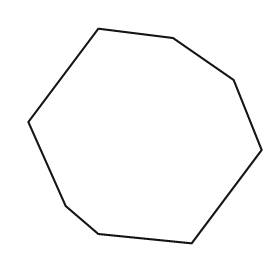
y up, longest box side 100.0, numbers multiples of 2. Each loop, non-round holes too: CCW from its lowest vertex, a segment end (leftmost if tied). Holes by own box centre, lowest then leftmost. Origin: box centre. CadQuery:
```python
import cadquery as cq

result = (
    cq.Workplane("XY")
    .moveTo(20.0, -46.0)
    .lineTo(50.0, -6.0)
    .lineTo(38.0, 24.0)
    .lineTo(12.0, 42.0)
    .lineTo(-20.0, 46.0)
    .lineTo(-50.0, 6.0)
    .lineTo(-34.0, -30.0)
    .lineTo(-20.0, -42.0)
    .close()
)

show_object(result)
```